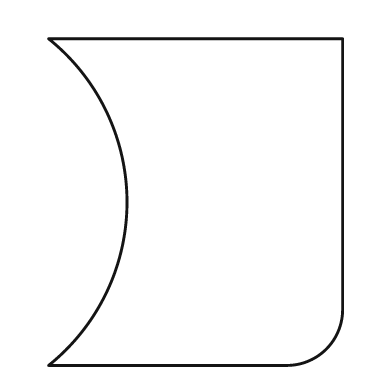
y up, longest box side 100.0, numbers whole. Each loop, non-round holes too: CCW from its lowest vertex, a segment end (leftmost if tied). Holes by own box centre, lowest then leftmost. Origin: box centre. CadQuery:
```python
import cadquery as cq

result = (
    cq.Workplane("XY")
    .moveTo(-45.0, -50.0)
    .lineTo(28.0, -50.0)
    .threePointArc((40.0, -45.0), (45.0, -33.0))
    .lineTo(45.0, 50.0)
    .lineTo(-45.0, 50.0)
    .threePointArc((-21.0, 0.0), (-45.0, -50.0))
    .close()
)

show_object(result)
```